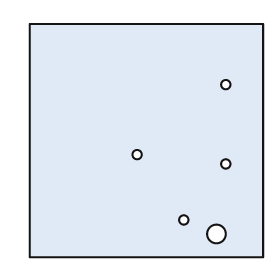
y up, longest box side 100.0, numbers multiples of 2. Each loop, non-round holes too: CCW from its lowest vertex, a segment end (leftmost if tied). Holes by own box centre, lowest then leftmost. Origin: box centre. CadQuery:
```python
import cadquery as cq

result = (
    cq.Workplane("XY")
    .moveTo(-50.0, -50.0)
    .lineTo(50.0, -50.0)
    .lineTo(50.0, 50.0)
    .lineTo(-50.0, 50.0)
    .close()
    .moveTo(30.0, -40.0)
    .circle(4.0)
    .moveTo(16.0, -34.0)
    .circle(2.0)
    .moveTo(34.0, -10.0)
    .circle(2.0)
    .moveTo(-4.0, -6.0)
    .circle(2.0)
    .moveTo(34.0, 24.0)
    .circle(2.0)
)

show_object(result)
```